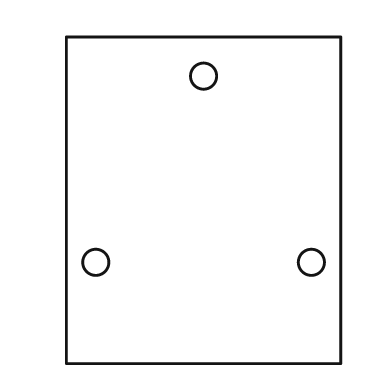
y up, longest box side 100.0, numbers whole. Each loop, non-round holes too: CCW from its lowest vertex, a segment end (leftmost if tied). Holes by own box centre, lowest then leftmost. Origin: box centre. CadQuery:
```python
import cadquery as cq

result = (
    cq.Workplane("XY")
    .moveTo(-42.0, -50.0)
    .lineTo(42.0, -50.0)
    .lineTo(42.0, 50.0)
    .lineTo(-42.0, 50.0)
    .close()
    .moveTo(-33.0, -19.0)
    .circle(4.0)
    .moveTo(33.0, -19.0)
    .circle(4.0)
    .moveTo(0.0, 38.0)
    .circle(4.0)
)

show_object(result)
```